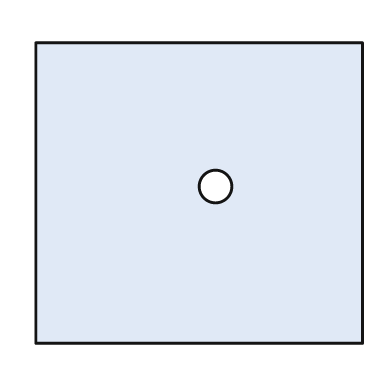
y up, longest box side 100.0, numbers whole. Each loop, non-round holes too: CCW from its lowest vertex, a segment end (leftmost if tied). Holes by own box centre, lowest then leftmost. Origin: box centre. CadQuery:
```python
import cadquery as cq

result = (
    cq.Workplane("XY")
    .moveTo(-50.0, -46.0)
    .lineTo(50.0, -46.0)
    .lineTo(50.0, 46.0)
    .lineTo(-50.0, 46.0)
    .close()
    .moveTo(5.0, 2.0)
    .circle(5.0)
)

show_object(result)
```